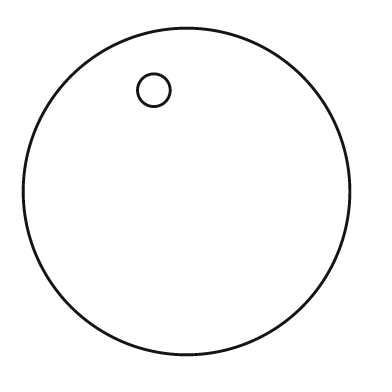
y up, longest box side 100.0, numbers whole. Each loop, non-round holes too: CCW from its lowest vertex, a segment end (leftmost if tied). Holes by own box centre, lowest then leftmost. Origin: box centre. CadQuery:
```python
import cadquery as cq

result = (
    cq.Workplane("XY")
    .moveTo(0.0, 0.0)
    .circle(50.0)
    .moveTo(-10.0, 31.0)
    .circle(5.0)
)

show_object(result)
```